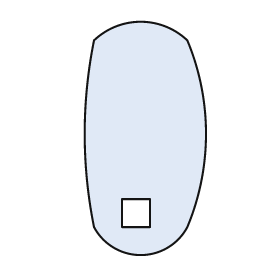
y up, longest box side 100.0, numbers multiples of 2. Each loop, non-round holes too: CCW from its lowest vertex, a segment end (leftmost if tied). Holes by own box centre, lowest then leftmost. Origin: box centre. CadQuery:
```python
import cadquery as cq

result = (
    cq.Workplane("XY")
    .moveTo(-22.0, -38.0)
    .threePointArc((-2.0, -50.0), (18.0, -38.0))
    .threePointArc((26.0, 2.0), (18.0, 42.0))
    .threePointArc((-2.0, 50.0), (-22.0, 42.0))
    .threePointArc((-26.0, 2.0), (-22.0, -38.0))
    .close()
    .moveTo(-10.0, -38.0)
    .lineTo(2.0, -38.0)
    .lineTo(2.0, -26.0)
    .lineTo(-10.0, -26.0)
    .close()
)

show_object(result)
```